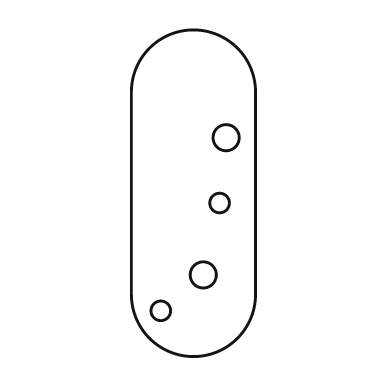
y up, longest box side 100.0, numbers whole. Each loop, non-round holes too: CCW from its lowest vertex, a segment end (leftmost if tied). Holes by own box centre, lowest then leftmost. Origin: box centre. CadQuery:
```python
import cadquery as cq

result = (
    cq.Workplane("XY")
    .moveTo(-19.0, -31.0)
    .threePointArc((0.0, -50.0), (19.0, -31.0))
    .lineTo(19.0, 31.0)
    .threePointArc((0.0, 50.0), (-19.0, 31.0))
    .close()
    .moveTo(-10.0, -36.0)
    .circle(3.0)
    .moveTo(3.0, -25.0)
    .circle(4.0)
    .moveTo(8.0, -3.0)
    .circle(3.0)
    .moveTo(10.0, 17.0)
    .circle(4.0)
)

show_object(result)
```